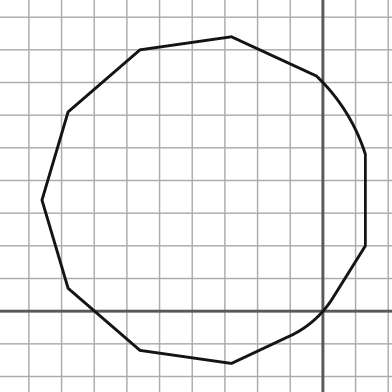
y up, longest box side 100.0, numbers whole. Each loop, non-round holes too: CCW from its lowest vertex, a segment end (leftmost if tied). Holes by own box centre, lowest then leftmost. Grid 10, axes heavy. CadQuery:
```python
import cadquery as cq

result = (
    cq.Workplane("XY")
    .moveTo(-28.0, -16.0)
    .lineTo(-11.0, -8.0)
    .threePointArc((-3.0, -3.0), (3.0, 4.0))
    .lineTo(13.0, 20.0)
    .lineTo(13.0, 48.0)
    .threePointArc((7.0, 61.0), (-2.0, 72.0))
    .lineTo(-28.0, 84.0)
    .lineTo(-56.0, 80.0)
    .lineTo(-78.0, 61.0)
    .lineTo(-86.0, 34.0)
    .lineTo(-78.0, 7.0)
    .lineTo(-56.0, -12.0)
    .close()
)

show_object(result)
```